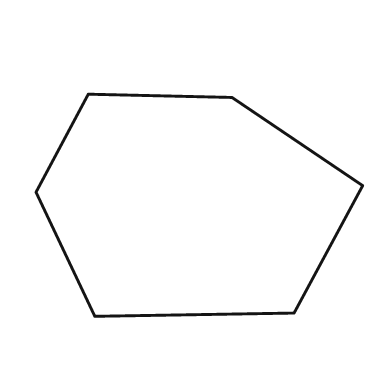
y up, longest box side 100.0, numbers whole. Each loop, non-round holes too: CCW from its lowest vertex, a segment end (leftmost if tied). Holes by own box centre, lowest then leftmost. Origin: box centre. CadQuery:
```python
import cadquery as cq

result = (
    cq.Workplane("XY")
    .moveTo(-32.0, -34.0)
    .lineTo(29.0, -33.0)
    .lineTo(50.0, 6.0)
    .lineTo(10.0, 33.0)
    .lineTo(-34.0, 34.0)
    .lineTo(-50.0, 4.0)
    .close()
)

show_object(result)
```